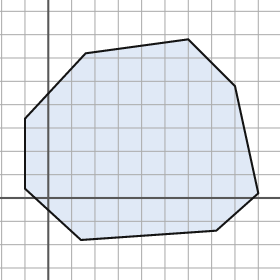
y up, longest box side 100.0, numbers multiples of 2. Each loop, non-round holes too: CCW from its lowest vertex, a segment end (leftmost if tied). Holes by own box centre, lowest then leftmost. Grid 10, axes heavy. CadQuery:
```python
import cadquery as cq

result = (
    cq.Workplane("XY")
    .moveTo(14.0, -18.0)
    .lineTo(72.0, -14.0)
    .lineTo(90.0, 2.0)
    .lineTo(80.0, 48.0)
    .lineTo(60.0, 68.0)
    .lineTo(16.0, 62.0)
    .lineTo(-10.0, 34.0)
    .lineTo(-10.0, 4.0)
    .close()
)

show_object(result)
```